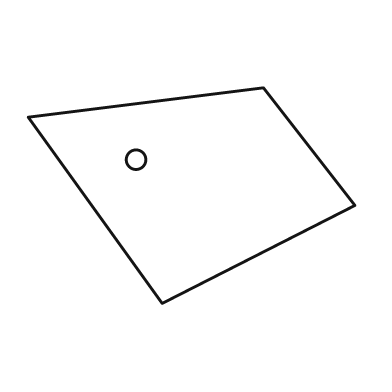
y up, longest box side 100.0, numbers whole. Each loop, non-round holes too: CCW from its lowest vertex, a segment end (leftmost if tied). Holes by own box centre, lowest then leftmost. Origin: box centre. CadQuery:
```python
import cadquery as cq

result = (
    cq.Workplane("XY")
    .moveTo(-9.0, -33.0)
    .lineTo(50.0, -3.0)
    .lineTo(22.0, 33.0)
    .lineTo(-50.0, 24.0)
    .close()
    .moveTo(-17.0, 11.0)
    .circle(3.0)
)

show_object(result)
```